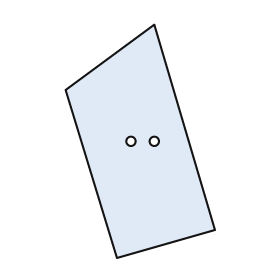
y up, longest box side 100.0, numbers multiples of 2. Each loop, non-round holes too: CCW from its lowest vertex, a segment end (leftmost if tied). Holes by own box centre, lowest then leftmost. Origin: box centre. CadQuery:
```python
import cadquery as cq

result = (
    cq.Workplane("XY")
    .moveTo(-10.0, -50.0)
    .lineTo(32.0, -38.0)
    .lineTo(6.0, 50.0)
    .lineTo(-32.0, 22.0)
    .close()
    .moveTo(-4.0, 0.0)
    .circle(2.0)
    .moveTo(6.0, 0.0)
    .circle(2.0)
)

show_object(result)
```